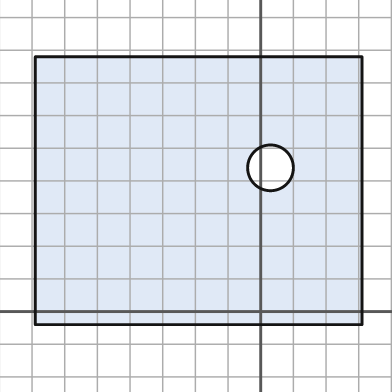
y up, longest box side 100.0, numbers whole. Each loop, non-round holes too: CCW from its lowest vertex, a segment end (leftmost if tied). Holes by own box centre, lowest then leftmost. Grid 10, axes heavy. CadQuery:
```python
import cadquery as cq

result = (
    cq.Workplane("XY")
    .moveTo(-69.0, -4.0)
    .lineTo(31.0, -4.0)
    .lineTo(31.0, 78.0)
    .lineTo(-69.0, 78.0)
    .close()
    .moveTo(3.0, 44.0)
    .circle(7.0)
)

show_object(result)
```